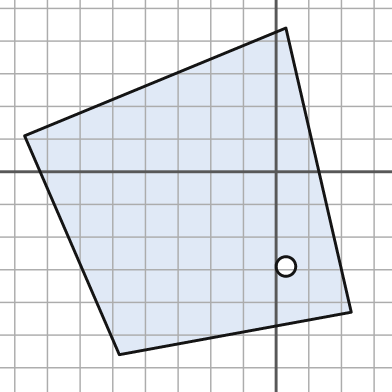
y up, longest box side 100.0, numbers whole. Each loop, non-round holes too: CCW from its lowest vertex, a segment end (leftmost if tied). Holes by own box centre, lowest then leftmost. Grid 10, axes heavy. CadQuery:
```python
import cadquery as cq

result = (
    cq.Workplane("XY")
    .moveTo(-48.0, -56.0)
    .lineTo(23.0, -43.0)
    .lineTo(3.0, 44.0)
    .lineTo(-77.0, 11.0)
    .close()
    .moveTo(3.0, -29.0)
    .circle(3.0)
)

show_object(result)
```